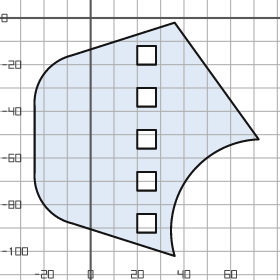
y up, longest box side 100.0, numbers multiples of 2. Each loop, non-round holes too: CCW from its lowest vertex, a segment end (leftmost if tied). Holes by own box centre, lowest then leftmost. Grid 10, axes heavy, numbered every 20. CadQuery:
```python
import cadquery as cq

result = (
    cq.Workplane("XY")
    .moveTo(36.0, -102.0)
    .threePointArc((42.0, -68.0), (72.0, -52.0))
    .lineTo(36.0, -2.0)
    .lineTo(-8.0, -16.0)
    .threePointArc((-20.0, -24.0), (-24.0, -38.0))
    .lineTo(-24.0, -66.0)
    .threePointArc((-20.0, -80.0), (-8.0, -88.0))
    .close()
    .moveTo(20.0, -92.0)
    .lineTo(28.0, -92.0)
    .lineTo(28.0, -84.0)
    .lineTo(20.0, -84.0)
    .close()
    .moveTo(20.0, -74.0)
    .lineTo(28.0, -74.0)
    .lineTo(28.0, -66.0)
    .lineTo(20.0, -66.0)
    .close()
    .moveTo(20.0, -56.0)
    .lineTo(28.0, -56.0)
    .lineTo(28.0, -48.0)
    .lineTo(20.0, -48.0)
    .close()
    .moveTo(20.0, -38.0)
    .lineTo(28.0, -38.0)
    .lineTo(28.0, -30.0)
    .lineTo(20.0, -30.0)
    .close()
    .moveTo(20.0, -20.0)
    .lineTo(28.0, -20.0)
    .lineTo(28.0, -12.0)
    .lineTo(20.0, -12.0)
    .close()
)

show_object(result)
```